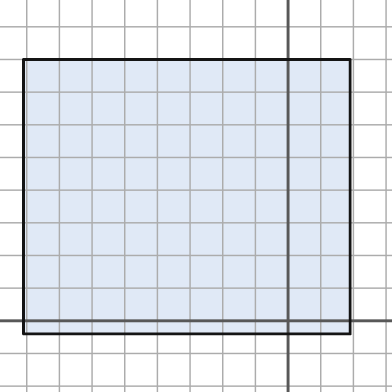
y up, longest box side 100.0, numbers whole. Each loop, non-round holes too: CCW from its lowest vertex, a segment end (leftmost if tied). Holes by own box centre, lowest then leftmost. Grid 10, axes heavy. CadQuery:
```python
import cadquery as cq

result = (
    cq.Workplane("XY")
    .moveTo(-81.0, -4.0)
    .lineTo(19.0, -4.0)
    .lineTo(19.0, 80.0)
    .lineTo(-81.0, 80.0)
    .close()
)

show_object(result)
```